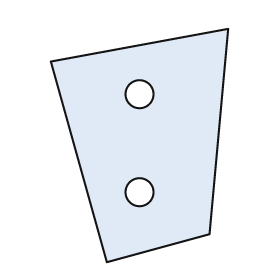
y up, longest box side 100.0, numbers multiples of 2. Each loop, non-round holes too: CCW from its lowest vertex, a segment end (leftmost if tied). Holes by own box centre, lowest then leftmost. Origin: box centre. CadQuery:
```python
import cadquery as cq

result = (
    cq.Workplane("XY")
    .moveTo(-14.0, -50.0)
    .lineTo(30.0, -38.0)
    .lineTo(38.0, 50.0)
    .lineTo(-38.0, 36.0)
    .close()
    .moveTo(0.0, -20.0)
    .circle(6.0)
    .moveTo(0.0, 22.0)
    .circle(6.0)
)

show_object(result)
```